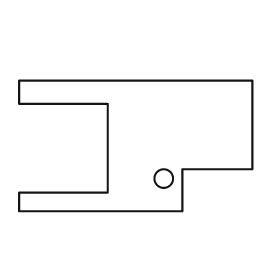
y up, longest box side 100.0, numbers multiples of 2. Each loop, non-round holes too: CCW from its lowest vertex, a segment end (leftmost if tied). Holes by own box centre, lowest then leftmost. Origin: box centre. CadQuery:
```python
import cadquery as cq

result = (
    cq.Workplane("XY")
    .moveTo(-50.0, -28.0)
    .lineTo(20.0, -28.0)
    .lineTo(20.0, -10.0)
    .lineTo(50.0, -10.0)
    .lineTo(50.0, 28.0)
    .lineTo(-50.0, 28.0)
    .lineTo(-50.0, 18.0)
    .lineTo(-12.0, 18.0)
    .lineTo(-12.0, -20.0)
    .lineTo(-50.0, -20.0)
    .close()
    .moveTo(12.0, -14.0)
    .circle(4.0)
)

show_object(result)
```